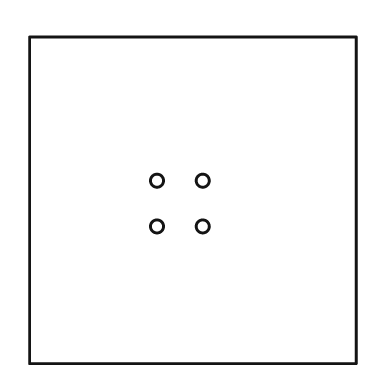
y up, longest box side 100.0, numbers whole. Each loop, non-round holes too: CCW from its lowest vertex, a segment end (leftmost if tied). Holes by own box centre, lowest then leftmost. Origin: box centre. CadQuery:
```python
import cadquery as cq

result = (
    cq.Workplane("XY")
    .moveTo(-50.0, -50.0)
    .lineTo(50.0, -50.0)
    .lineTo(50.0, 50.0)
    .lineTo(-50.0, 50.0)
    .close()
    .moveTo(-11.0, -8.0)
    .circle(2.0)
    .moveTo(3.0, -8.0)
    .circle(2.0)
    .moveTo(-11.0, 6.0)
    .circle(2.0)
    .moveTo(3.0, 6.0)
    .circle(2.0)
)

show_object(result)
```